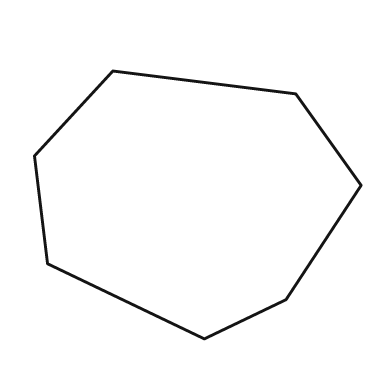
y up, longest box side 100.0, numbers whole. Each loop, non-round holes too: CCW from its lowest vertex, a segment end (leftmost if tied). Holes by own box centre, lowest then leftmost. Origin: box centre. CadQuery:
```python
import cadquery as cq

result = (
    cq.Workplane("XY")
    .moveTo(2.0, -41.0)
    .lineTo(27.0, -29.0)
    .lineTo(50.0, 6.0)
    .lineTo(30.0, 34.0)
    .lineTo(-26.0, 41.0)
    .lineTo(-50.0, 15.0)
    .lineTo(-46.0, -18.0)
    .close()
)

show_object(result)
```